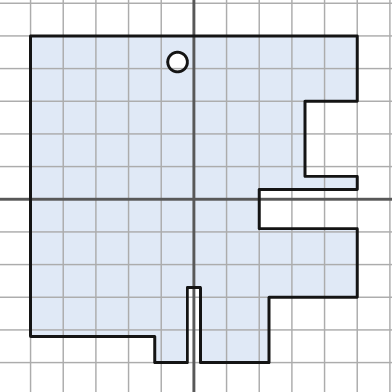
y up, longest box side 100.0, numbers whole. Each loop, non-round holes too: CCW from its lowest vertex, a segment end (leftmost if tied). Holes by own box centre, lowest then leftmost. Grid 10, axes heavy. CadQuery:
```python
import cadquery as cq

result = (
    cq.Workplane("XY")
    .moveTo(-12.0, -50.0)
    .lineTo(-2.0, -50.0)
    .lineTo(-2.0, -27.0)
    .lineTo(2.0, -27.0)
    .lineTo(2.0, -50.0)
    .lineTo(23.0, -50.0)
    .lineTo(23.0, -30.0)
    .lineTo(50.0, -30.0)
    .lineTo(50.0, -9.0)
    .lineTo(20.0, -9.0)
    .lineTo(20.0, 3.0)
    .lineTo(50.0, 3.0)
    .lineTo(50.0, 7.0)
    .lineTo(34.0, 7.0)
    .lineTo(34.0, 30.0)
    .lineTo(50.0, 30.0)
    .lineTo(50.0, 50.0)
    .lineTo(-50.0, 50.0)
    .lineTo(-50.0, -42.0)
    .lineTo(-12.0, -42.0)
    .close()
    .moveTo(-5.0, 42.0)
    .circle(3.0)
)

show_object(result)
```